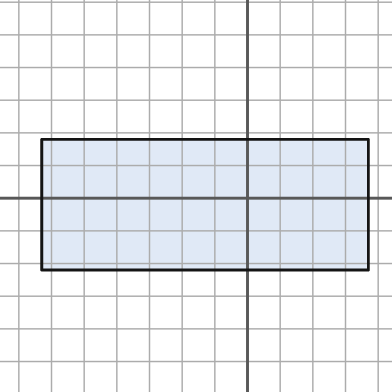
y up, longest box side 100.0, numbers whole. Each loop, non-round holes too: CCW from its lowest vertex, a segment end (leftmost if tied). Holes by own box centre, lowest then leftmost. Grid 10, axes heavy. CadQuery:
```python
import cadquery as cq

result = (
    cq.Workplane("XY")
    .moveTo(-63.0, -22.0)
    .lineTo(37.0, -22.0)
    .lineTo(37.0, 18.0)
    .lineTo(-63.0, 18.0)
    .close()
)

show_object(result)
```